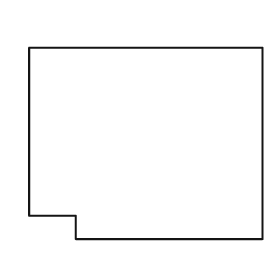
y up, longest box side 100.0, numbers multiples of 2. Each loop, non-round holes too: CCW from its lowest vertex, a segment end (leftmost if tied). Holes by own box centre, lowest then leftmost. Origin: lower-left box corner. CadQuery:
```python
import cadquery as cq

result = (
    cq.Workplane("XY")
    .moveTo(20.0, 0.0)
    .lineTo(100.0, 0.0)
    .lineTo(100.0, 82.0)
    .lineTo(0.0, 82.0)
    .lineTo(0.0, 10.0)
    .lineTo(20.0, 10.0)
    .close()
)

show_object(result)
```